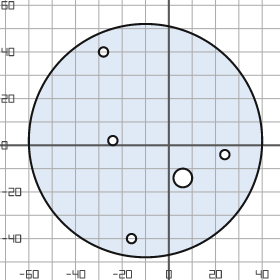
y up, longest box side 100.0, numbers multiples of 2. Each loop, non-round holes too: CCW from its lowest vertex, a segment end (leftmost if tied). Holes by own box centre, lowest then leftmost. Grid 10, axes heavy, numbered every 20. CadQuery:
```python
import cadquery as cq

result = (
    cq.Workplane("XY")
    .moveTo(-10.0, 2.0)
    .circle(50.0)
    .moveTo(-16.0, -40.0)
    .circle(2.0)
    .moveTo(6.0, -14.0)
    .circle(4.0)
    .moveTo(24.0, -4.0)
    .circle(2.0)
    .moveTo(-24.0, 2.0)
    .circle(2.0)
    .moveTo(-28.0, 40.0)
    .circle(2.0)
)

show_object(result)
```